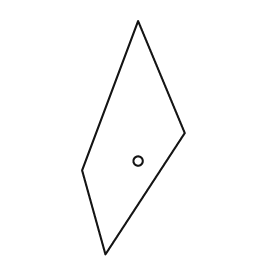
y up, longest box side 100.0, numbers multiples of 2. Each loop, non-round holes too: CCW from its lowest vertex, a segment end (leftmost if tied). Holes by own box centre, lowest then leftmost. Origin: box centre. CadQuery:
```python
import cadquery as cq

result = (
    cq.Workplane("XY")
    .moveTo(-12.0, -50.0)
    .lineTo(22.0, 2.0)
    .lineTo(2.0, 50.0)
    .lineTo(-22.0, -14.0)
    .close()
    .moveTo(2.0, -10.0)
    .circle(2.0)
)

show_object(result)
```